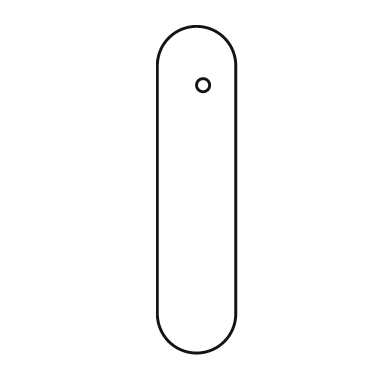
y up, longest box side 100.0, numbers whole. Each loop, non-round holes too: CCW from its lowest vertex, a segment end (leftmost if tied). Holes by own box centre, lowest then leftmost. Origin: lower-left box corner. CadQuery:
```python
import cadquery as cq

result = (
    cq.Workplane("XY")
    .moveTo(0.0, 12.0)
    .threePointArc((12.0, 0.0), (24.0, 12.0))
    .lineTo(24.0, 88.0)
    .threePointArc((12.0, 100.0), (0.0, 88.0))
    .close()
    .moveTo(14.0, 82.0)
    .circle(2.0)
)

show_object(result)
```